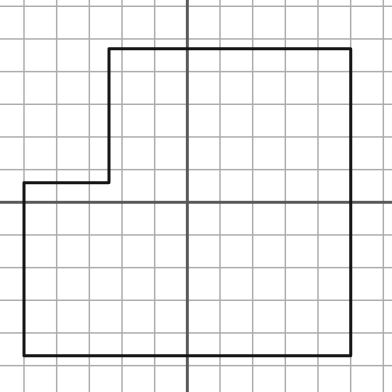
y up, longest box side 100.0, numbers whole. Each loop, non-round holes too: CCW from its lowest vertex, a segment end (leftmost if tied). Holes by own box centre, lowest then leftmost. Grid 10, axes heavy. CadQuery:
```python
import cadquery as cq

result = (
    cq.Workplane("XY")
    .moveTo(-50.0, -47.0)
    .lineTo(50.0, -47.0)
    .lineTo(50.0, 47.0)
    .lineTo(-24.0, 47.0)
    .lineTo(-24.0, 6.0)
    .lineTo(-50.0, 6.0)
    .close()
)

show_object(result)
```